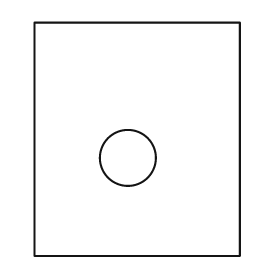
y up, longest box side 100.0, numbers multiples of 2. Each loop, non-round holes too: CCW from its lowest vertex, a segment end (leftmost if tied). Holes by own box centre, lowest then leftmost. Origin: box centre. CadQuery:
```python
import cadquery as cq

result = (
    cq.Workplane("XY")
    .moveTo(-44.0, -50.0)
    .lineTo(44.0, -50.0)
    .lineTo(44.0, 50.0)
    .lineTo(-44.0, 50.0)
    .close()
    .moveTo(-4.0, -8.0)
    .circle(12.0)
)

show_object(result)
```